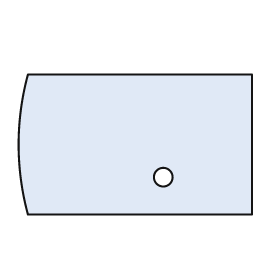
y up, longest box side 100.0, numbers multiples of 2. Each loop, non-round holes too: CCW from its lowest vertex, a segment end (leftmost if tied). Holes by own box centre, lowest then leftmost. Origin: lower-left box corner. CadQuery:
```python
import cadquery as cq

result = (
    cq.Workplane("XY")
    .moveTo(4.0, 0.0)
    .lineTo(100.0, 0.0)
    .lineTo(100.0, 60.0)
    .lineTo(4.0, 60.0)
    .threePointArc((0.0, 30.0), (4.0, 0.0))
    .close()
    .moveTo(62.0, 16.0)
    .circle(4.0)
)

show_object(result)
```